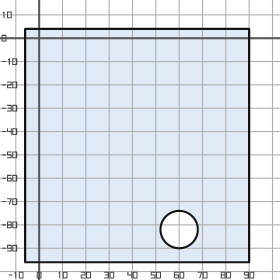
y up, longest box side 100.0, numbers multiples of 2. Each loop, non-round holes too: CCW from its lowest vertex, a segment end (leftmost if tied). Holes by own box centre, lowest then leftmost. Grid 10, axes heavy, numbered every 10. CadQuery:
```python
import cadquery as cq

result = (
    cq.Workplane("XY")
    .moveTo(-6.0, -96.0)
    .lineTo(90.0, -96.0)
    .lineTo(90.0, 4.0)
    .lineTo(-6.0, 4.0)
    .close()
    .moveTo(60.0, -82.0)
    .circle(8.0)
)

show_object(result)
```